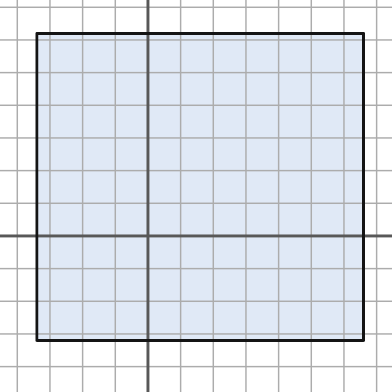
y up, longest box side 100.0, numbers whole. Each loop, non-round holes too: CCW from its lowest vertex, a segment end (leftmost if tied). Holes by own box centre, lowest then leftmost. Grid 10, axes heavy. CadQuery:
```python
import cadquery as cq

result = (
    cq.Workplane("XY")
    .moveTo(-34.0, -32.0)
    .lineTo(66.0, -32.0)
    .lineTo(66.0, 62.0)
    .lineTo(-34.0, 62.0)
    .close()
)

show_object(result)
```